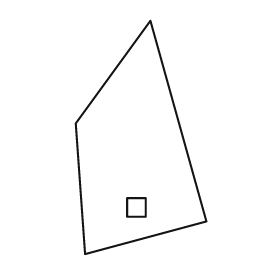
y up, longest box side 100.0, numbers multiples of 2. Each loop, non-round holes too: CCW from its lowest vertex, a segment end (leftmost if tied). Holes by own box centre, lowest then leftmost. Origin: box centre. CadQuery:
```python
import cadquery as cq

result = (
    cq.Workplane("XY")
    .moveTo(-24.0, -50.0)
    .lineTo(28.0, -36.0)
    .lineTo(4.0, 50.0)
    .lineTo(-28.0, 6.0)
    .close()
    .moveTo(-6.0, -34.0)
    .lineTo(2.0, -34.0)
    .lineTo(2.0, -26.0)
    .lineTo(-6.0, -26.0)
    .close()
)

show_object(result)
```